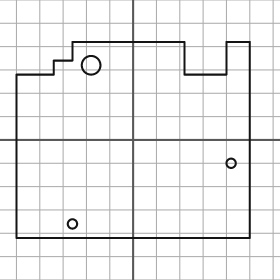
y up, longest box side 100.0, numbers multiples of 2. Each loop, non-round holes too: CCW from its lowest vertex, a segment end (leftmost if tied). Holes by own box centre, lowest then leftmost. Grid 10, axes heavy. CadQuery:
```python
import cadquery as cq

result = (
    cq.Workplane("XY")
    .moveTo(-50.0, -42.0)
    .lineTo(50.0, -42.0)
    .lineTo(50.0, 42.0)
    .lineTo(40.0, 42.0)
    .lineTo(40.0, 28.0)
    .lineTo(22.0, 28.0)
    .lineTo(22.0, 42.0)
    .lineTo(-26.0, 42.0)
    .lineTo(-26.0, 34.0)
    .lineTo(-34.0, 34.0)
    .lineTo(-34.0, 28.0)
    .lineTo(-50.0, 28.0)
    .close()
    .moveTo(-26.0, -36.0)
    .circle(2.0)
    .moveTo(42.0, -10.0)
    .circle(2.0)
    .moveTo(-18.0, 32.0)
    .circle(4.0)
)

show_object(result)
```